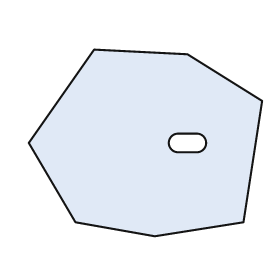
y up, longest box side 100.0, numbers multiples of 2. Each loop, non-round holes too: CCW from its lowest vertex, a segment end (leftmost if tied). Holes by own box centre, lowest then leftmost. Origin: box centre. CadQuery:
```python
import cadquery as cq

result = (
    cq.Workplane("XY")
    .moveTo(4.0, -40.0)
    .lineTo(42.0, -34.0)
    .lineTo(50.0, 18.0)
    .lineTo(18.0, 38.0)
    .lineTo(-22.0, 40.0)
    .lineTo(-50.0, 0.0)
    .lineTo(-30.0, -34.0)
    .close()
    .moveTo(14.0, -4.0)
    .lineTo(22.0, -4.0)
    .threePointArc((26.0, 0.0), (22.0, 4.0))
    .lineTo(14.0, 4.0)
    .threePointArc((10.0, 0.0), (14.0, -4.0))
    .close()
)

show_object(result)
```